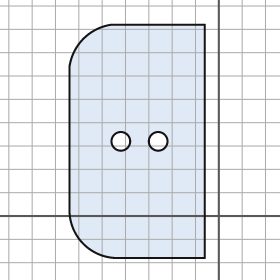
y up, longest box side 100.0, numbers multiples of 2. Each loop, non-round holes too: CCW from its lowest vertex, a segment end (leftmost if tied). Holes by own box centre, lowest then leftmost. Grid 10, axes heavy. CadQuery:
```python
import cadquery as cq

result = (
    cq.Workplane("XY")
    .moveTo(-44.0, -18.0)
    .lineTo(-6.0, -18.0)
    .lineTo(-6.0, 82.0)
    .lineTo(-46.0, 82.0)
    .threePointArc((-58.0, 76.0), (-64.0, 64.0))
    .lineTo(-64.0, 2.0)
    .threePointArc((-58.0, -12.0), (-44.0, -18.0))
    .close()
    .moveTo(-42.0, 32.0)
    .circle(4.0)
    .moveTo(-26.0, 32.0)
    .circle(4.0)
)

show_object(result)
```